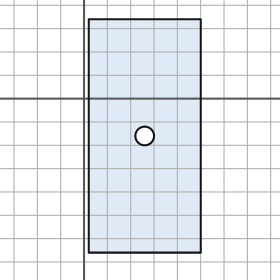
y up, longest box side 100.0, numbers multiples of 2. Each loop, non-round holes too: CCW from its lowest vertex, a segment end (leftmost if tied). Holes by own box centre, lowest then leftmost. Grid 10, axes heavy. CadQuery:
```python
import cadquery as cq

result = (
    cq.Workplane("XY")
    .moveTo(2.0, -66.0)
    .lineTo(50.0, -66.0)
    .lineTo(50.0, 34.0)
    .lineTo(2.0, 34.0)
    .close()
    .moveTo(26.0, -16.0)
    .circle(4.0)
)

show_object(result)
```